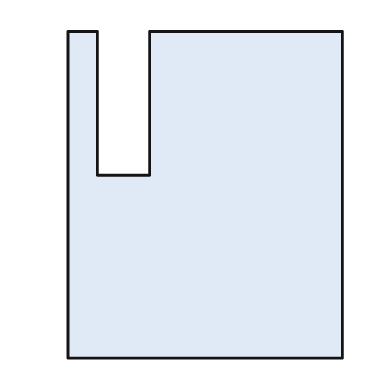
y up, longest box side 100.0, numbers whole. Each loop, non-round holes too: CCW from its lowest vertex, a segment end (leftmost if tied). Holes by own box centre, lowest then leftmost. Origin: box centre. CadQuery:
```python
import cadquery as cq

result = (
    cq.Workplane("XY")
    .moveTo(-42.0, -50.0)
    .lineTo(42.0, -50.0)
    .lineTo(42.0, 50.0)
    .lineTo(-17.0, 50.0)
    .lineTo(-17.0, 6.0)
    .lineTo(-33.0, 6.0)
    .lineTo(-33.0, 50.0)
    .lineTo(-42.0, 50.0)
    .close()
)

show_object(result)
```